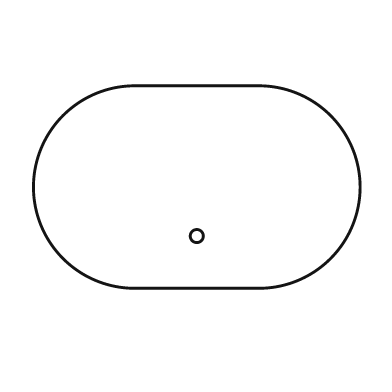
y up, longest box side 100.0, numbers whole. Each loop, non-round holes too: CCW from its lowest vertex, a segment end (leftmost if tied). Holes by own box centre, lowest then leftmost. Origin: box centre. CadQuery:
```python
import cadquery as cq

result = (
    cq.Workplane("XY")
    .moveTo(-19.0, -31.0)
    .lineTo(19.0, -31.0)
    .threePointArc((50.0, 0.0), (19.0, 31.0))
    .lineTo(-19.0, 31.0)
    .threePointArc((-50.0, 0.0), (-19.0, -31.0))
    .close()
    .moveTo(0.0, -15.0)
    .circle(2.0)
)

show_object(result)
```